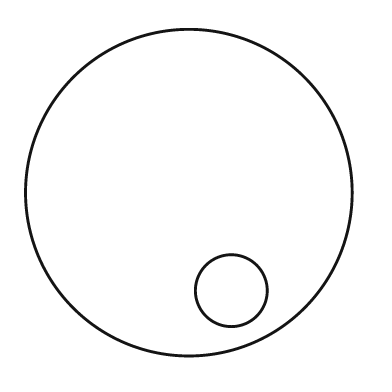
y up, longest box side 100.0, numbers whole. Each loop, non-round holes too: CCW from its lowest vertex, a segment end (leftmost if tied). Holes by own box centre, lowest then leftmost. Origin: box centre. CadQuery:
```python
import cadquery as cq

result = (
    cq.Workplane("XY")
    .moveTo(0.0, 0.0)
    .circle(50.0)
    .moveTo(13.0, -30.0)
    .circle(11.0)
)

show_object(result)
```